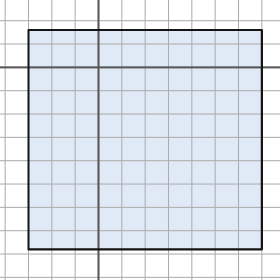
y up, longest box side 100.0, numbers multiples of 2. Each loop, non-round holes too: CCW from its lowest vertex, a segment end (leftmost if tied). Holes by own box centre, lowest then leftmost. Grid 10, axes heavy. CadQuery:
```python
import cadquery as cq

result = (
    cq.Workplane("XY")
    .moveTo(-30.0, -78.0)
    .lineTo(70.0, -78.0)
    .lineTo(70.0, 16.0)
    .lineTo(-30.0, 16.0)
    .close()
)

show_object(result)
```